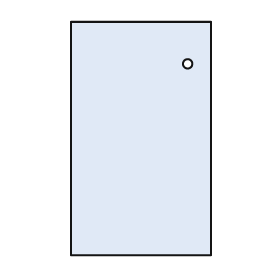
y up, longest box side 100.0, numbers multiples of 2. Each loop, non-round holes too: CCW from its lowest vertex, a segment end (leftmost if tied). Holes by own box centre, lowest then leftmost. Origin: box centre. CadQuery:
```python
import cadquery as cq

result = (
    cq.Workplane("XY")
    .moveTo(-30.0, -50.0)
    .lineTo(30.0, -50.0)
    .lineTo(30.0, 50.0)
    .lineTo(-30.0, 50.0)
    .close()
    .moveTo(20.0, 32.0)
    .circle(2.0)
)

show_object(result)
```